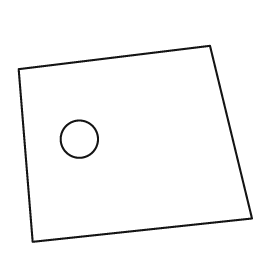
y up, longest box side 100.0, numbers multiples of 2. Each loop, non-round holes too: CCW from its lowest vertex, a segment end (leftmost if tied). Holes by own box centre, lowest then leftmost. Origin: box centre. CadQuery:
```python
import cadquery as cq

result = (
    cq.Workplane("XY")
    .moveTo(-44.0, -42.0)
    .lineTo(50.0, -32.0)
    .lineTo(32.0, 42.0)
    .lineTo(-50.0, 32.0)
    .close()
    .moveTo(-24.0, 2.0)
    .circle(8.0)
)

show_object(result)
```